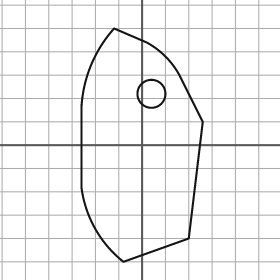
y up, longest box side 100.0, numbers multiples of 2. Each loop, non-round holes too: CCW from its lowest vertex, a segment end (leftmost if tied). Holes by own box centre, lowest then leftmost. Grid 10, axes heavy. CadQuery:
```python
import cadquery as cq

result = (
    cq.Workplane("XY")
    .moveTo(-8.0, -50.0)
    .lineTo(20.0, -40.0)
    .lineTo(26.0, 10.0)
    .lineTo(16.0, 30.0)
    .threePointArc((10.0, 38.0), (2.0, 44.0))
    .lineTo(-12.0, 50.0)
    .threePointArc((-22.0, 34.0), (-26.0, 16.0))
    .lineTo(-26.0, -18.0)
    .threePointArc((-20.0, -36.0), (-8.0, -50.0))
    .close()
    .moveTo(4.0, 22.0)
    .circle(6.0)
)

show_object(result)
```